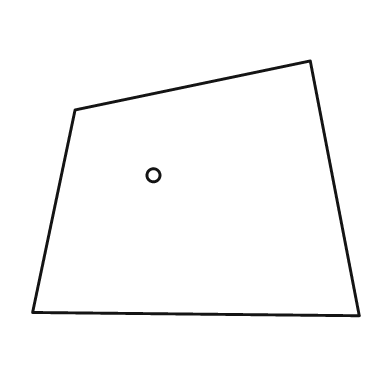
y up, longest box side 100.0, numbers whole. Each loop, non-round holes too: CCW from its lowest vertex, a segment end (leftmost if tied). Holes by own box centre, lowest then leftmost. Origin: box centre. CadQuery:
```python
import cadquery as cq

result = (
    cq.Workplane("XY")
    .moveTo(50.0, -39.0)
    .lineTo(35.0, 39.0)
    .lineTo(-37.0, 24.0)
    .lineTo(-50.0, -38.0)
    .close()
    .moveTo(-13.0, 4.0)
    .circle(2.0)
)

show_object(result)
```